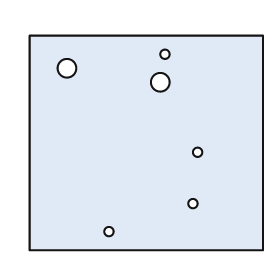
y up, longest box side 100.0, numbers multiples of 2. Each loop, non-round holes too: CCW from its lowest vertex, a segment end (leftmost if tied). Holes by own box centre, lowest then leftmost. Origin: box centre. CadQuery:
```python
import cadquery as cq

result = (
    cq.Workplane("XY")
    .moveTo(-50.0, -46.0)
    .lineTo(50.0, -46.0)
    .lineTo(50.0, 46.0)
    .lineTo(-50.0, 46.0)
    .close()
    .moveTo(-16.0, -38.0)
    .circle(2.0)
    .moveTo(20.0, -26.0)
    .circle(2.0)
    .moveTo(22.0, -4.0)
    .circle(2.0)
    .moveTo(6.0, 26.0)
    .circle(4.0)
    .moveTo(-34.0, 32.0)
    .circle(4.0)
    .moveTo(8.0, 38.0)
    .circle(2.0)
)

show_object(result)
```